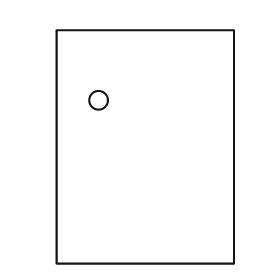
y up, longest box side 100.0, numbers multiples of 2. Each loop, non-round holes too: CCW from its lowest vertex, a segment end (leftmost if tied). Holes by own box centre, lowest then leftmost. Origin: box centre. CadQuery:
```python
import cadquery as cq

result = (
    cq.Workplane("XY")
    .moveTo(-38.0, -50.0)
    .lineTo(38.0, -50.0)
    .lineTo(38.0, 50.0)
    .lineTo(-38.0, 50.0)
    .close()
    .moveTo(-20.0, 20.0)
    .circle(4.0)
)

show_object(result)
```